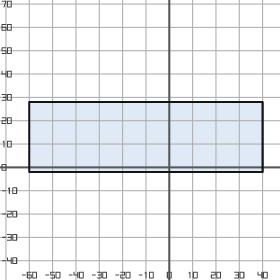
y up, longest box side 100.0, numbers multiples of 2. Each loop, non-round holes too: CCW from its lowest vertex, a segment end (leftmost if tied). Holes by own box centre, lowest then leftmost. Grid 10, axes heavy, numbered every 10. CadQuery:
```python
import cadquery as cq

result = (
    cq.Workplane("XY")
    .moveTo(-60.0, -2.0)
    .lineTo(40.0, -2.0)
    .lineTo(40.0, 28.0)
    .lineTo(-60.0, 28.0)
    .close()
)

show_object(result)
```